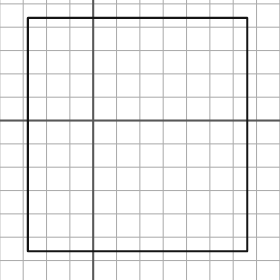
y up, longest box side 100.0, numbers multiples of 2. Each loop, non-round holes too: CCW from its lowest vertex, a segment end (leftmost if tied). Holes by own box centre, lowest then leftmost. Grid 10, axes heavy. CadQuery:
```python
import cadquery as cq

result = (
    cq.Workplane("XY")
    .moveTo(-28.0, -56.0)
    .lineTo(66.0, -56.0)
    .lineTo(66.0, 44.0)
    .lineTo(-28.0, 44.0)
    .close()
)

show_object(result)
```